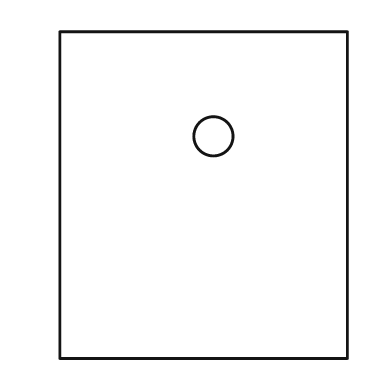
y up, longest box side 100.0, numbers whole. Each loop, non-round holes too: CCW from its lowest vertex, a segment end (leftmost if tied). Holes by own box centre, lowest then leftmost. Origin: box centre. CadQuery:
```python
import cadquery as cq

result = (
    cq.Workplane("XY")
    .moveTo(-44.0, -50.0)
    .lineTo(44.0, -50.0)
    .lineTo(44.0, 50.0)
    .lineTo(-44.0, 50.0)
    .close()
    .moveTo(3.0, 18.0)
    .circle(6.0)
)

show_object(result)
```